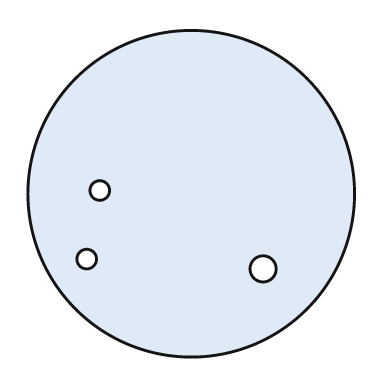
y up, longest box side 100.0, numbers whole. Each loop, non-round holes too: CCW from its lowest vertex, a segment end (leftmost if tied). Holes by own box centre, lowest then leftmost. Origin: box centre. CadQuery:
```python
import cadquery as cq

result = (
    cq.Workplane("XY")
    .moveTo(0.0, 0.0)
    .circle(50.0)
    .moveTo(22.0, -23.0)
    .circle(4.0)
    .moveTo(-32.0, -20.0)
    .circle(3.0)
    .moveTo(-28.0, 1.0)
    .circle(3.0)
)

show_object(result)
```